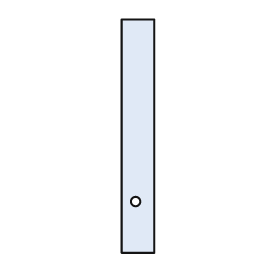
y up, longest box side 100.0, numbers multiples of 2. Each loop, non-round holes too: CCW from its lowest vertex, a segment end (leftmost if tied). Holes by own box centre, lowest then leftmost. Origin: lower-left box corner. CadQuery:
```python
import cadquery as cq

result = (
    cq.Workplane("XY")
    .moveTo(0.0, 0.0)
    .lineTo(14.0, 0.0)
    .lineTo(14.0, 100.0)
    .lineTo(0.0, 100.0)
    .close()
    .moveTo(6.0, 22.0)
    .circle(2.0)
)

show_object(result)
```